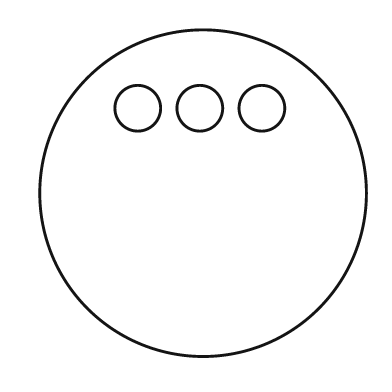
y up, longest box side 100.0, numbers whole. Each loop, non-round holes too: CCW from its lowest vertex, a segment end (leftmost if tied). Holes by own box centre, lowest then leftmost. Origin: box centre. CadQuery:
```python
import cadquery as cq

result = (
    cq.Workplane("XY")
    .moveTo(0.0, 0.0)
    .circle(50.0)
    .moveTo(-20.0, 26.0)
    .circle(7.0)
    .moveTo(-1.0, 26.0)
    .circle(7.0)
    .moveTo(18.0, 26.0)
    .circle(7.0)
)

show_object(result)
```